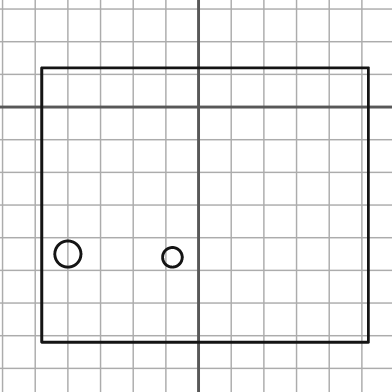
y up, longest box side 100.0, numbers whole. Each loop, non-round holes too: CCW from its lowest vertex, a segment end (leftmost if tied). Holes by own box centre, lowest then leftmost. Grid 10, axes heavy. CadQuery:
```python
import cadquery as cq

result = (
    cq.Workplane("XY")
    .moveTo(-48.0, -72.0)
    .lineTo(52.0, -72.0)
    .lineTo(52.0, 12.0)
    .lineTo(-48.0, 12.0)
    .close()
    .moveTo(-8.0, -46.0)
    .circle(3.0)
    .moveTo(-40.0, -45.0)
    .circle(4.0)
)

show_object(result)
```